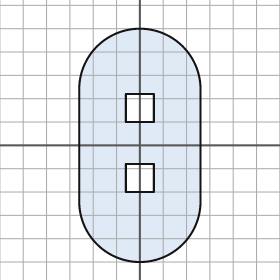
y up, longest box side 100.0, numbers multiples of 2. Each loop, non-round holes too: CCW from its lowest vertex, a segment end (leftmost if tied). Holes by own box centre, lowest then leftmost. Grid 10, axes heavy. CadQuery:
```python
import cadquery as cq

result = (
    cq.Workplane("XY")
    .moveTo(-26.0, -24.0)
    .threePointArc((0.0, -50.0), (26.0, -24.0))
    .lineTo(26.0, 24.0)
    .threePointArc((0.0, 50.0), (-26.0, 24.0))
    .close()
    .moveTo(-6.0, -20.0)
    .lineTo(6.0, -20.0)
    .lineTo(6.0, -8.0)
    .lineTo(-6.0, -8.0)
    .close()
    .moveTo(-6.0, 10.0)
    .lineTo(6.0, 10.0)
    .lineTo(6.0, 22.0)
    .lineTo(-6.0, 22.0)
    .close()
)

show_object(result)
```